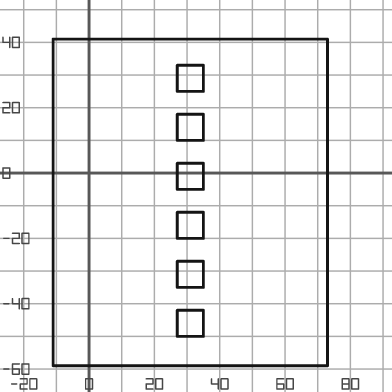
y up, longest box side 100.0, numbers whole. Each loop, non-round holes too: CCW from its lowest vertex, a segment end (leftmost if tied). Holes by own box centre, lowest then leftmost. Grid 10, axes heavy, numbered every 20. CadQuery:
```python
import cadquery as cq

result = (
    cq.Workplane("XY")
    .moveTo(-11.0, -59.0)
    .lineTo(73.0, -59.0)
    .lineTo(73.0, 41.0)
    .lineTo(-11.0, 41.0)
    .close()
    .moveTo(27.0, -50.0)
    .lineTo(35.0, -50.0)
    .lineTo(35.0, -42.0)
    .lineTo(27.0, -42.0)
    .close()
    .moveTo(27.0, -35.0)
    .lineTo(35.0, -35.0)
    .lineTo(35.0, -27.0)
    .lineTo(27.0, -27.0)
    .close()
    .moveTo(27.0, -20.0)
    .lineTo(35.0, -20.0)
    .lineTo(35.0, -12.0)
    .lineTo(27.0, -12.0)
    .close()
    .moveTo(27.0, -5.0)
    .lineTo(35.0, -5.0)
    .lineTo(35.0, 3.0)
    .lineTo(27.0, 3.0)
    .close()
    .moveTo(27.0, 10.0)
    .lineTo(35.0, 10.0)
    .lineTo(35.0, 18.0)
    .lineTo(27.0, 18.0)
    .close()
    .moveTo(27.0, 25.0)
    .lineTo(35.0, 25.0)
    .lineTo(35.0, 33.0)
    .lineTo(27.0, 33.0)
    .close()
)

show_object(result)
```